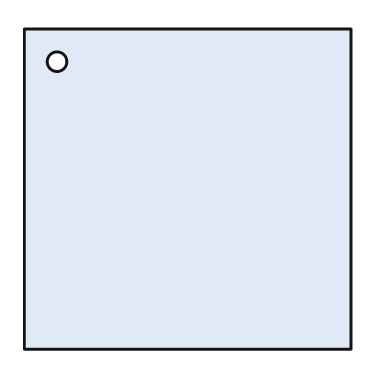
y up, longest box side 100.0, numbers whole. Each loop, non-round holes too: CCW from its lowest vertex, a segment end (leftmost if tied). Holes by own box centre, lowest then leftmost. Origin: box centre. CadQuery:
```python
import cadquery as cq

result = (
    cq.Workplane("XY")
    .moveTo(-50.0, -49.0)
    .lineTo(50.0, -49.0)
    .lineTo(50.0, 49.0)
    .lineTo(-50.0, 49.0)
    .close()
    .moveTo(-40.0, 39.0)
    .circle(3.0)
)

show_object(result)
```